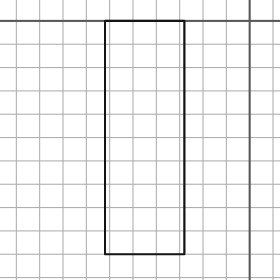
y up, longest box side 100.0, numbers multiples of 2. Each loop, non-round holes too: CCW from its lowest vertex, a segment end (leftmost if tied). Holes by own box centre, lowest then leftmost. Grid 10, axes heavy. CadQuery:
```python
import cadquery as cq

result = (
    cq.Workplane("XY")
    .moveTo(-62.0, -100.0)
    .lineTo(-28.0, -100.0)
    .lineTo(-28.0, 0.0)
    .lineTo(-62.0, 0.0)
    .close()
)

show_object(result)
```